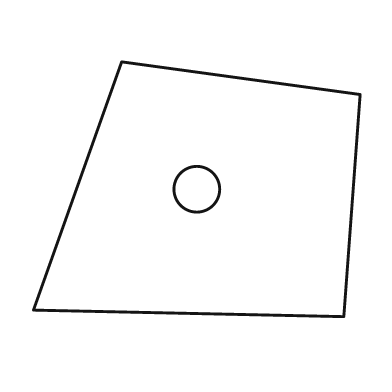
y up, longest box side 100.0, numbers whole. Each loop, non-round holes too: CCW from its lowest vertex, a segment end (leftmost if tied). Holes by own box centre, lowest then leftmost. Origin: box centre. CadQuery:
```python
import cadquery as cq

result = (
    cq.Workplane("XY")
    .moveTo(45.0, -39.0)
    .lineTo(50.0, 29.0)
    .lineTo(-23.0, 39.0)
    .lineTo(-50.0, -37.0)
    .close()
    .moveTo(0.0, 0.0)
    .circle(7.0)
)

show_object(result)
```